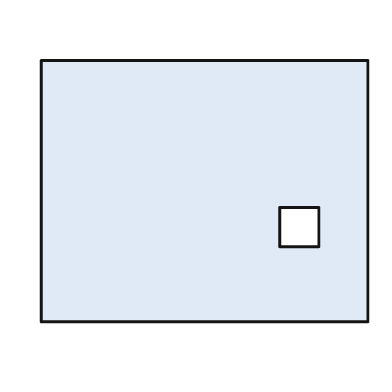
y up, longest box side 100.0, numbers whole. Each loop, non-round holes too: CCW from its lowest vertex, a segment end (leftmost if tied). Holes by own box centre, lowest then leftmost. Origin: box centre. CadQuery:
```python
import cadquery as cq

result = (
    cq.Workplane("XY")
    .moveTo(-50.0, -40.0)
    .lineTo(50.0, -40.0)
    .lineTo(50.0, 40.0)
    .lineTo(-50.0, 40.0)
    .close()
    .moveTo(23.0, -17.0)
    .lineTo(35.0, -17.0)
    .lineTo(35.0, -5.0)
    .lineTo(23.0, -5.0)
    .close()
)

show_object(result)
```